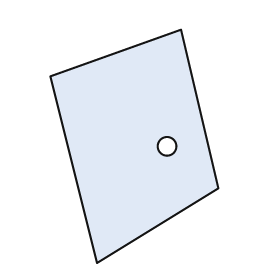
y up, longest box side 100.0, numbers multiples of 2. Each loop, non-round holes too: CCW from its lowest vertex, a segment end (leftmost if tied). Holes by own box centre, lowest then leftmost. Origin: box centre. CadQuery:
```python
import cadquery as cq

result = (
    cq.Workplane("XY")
    .moveTo(-16.0, -50.0)
    .lineTo(36.0, -18.0)
    .lineTo(20.0, 50.0)
    .lineTo(-36.0, 30.0)
    .close()
    .moveTo(14.0, 0.0)
    .circle(4.0)
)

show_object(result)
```